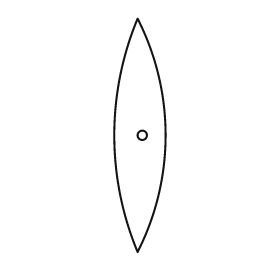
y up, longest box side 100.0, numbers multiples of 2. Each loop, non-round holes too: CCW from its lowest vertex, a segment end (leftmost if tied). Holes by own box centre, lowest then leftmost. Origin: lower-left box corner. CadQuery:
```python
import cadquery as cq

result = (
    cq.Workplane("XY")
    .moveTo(10.0, 0.0)
    .threePointArc((22.0, 50.0), (10.0, 100.0))
    .threePointArc((0.0, 50.0), (10.0, 0.0))
    .close()
    .moveTo(12.0, 50.0)
    .circle(2.0)
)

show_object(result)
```